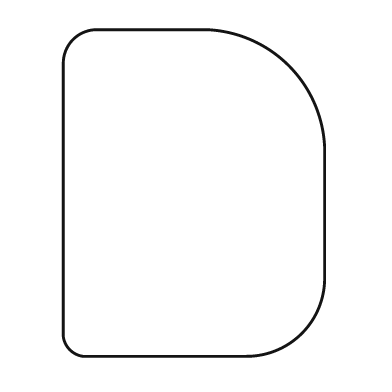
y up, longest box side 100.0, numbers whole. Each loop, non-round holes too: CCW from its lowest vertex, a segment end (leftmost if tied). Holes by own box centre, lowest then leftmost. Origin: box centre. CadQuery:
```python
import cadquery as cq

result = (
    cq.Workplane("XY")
    .moveTo(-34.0, -50.0)
    .lineTo(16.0, -50.0)
    .threePointArc((33.0, -43.0), (40.0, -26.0))
    .lineTo(40.0, 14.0)
    .threePointArc((29.0, 39.0), (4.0, 50.0))
    .lineTo(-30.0, 50.0)
    .threePointArc((-37.0, 47.0), (-40.0, 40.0))
    .lineTo(-40.0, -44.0)
    .threePointArc((-38.0, -48.0), (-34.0, -50.0))
    .close()
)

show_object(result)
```